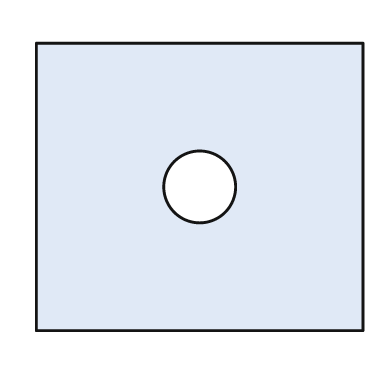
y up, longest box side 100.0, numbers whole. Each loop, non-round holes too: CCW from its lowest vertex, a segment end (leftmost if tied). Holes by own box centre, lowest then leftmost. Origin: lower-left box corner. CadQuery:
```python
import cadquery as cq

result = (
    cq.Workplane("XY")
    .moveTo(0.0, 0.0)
    .lineTo(100.0, 0.0)
    .lineTo(100.0, 88.0)
    .lineTo(0.0, 88.0)
    .close()
    .moveTo(50.0, 44.0)
    .circle(11.0)
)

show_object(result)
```